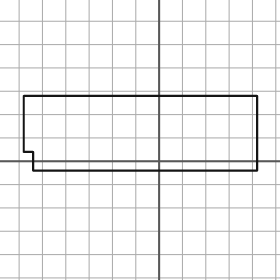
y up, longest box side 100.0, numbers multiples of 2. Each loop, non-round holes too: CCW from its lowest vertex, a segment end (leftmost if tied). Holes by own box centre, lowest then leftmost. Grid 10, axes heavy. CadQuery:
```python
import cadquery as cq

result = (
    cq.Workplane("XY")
    .moveTo(-54.0, -4.0)
    .lineTo(42.0, -4.0)
    .lineTo(42.0, 28.0)
    .lineTo(-58.0, 28.0)
    .lineTo(-58.0, 4.0)
    .lineTo(-54.0, 4.0)
    .close()
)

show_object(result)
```